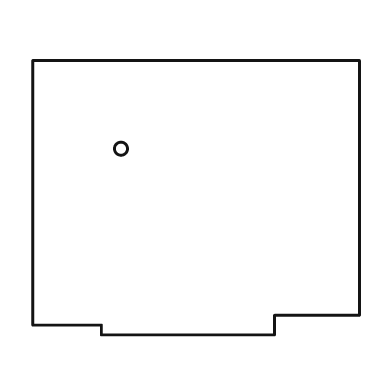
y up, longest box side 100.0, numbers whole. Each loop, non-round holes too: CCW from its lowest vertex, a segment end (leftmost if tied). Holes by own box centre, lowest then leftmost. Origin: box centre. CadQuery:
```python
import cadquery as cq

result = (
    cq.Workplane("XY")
    .moveTo(-29.0, -42.0)
    .lineTo(24.0, -42.0)
    .lineTo(24.0, -36.0)
    .lineTo(50.0, -36.0)
    .lineTo(50.0, 42.0)
    .lineTo(-50.0, 42.0)
    .lineTo(-50.0, -39.0)
    .lineTo(-29.0, -39.0)
    .close()
    .moveTo(-23.0, 15.0)
    .circle(2.0)
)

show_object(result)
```